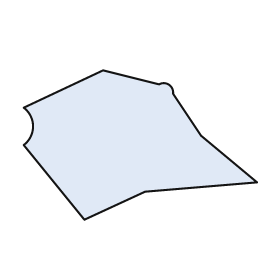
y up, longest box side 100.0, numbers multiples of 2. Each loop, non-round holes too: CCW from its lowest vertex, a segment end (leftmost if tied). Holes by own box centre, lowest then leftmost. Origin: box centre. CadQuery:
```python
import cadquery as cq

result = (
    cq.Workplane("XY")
    .moveTo(-24.0, -32.0)
    .lineTo(2.0, -20.0)
    .lineTo(50.0, -16.0)
    .lineTo(26.0, 4.0)
    .lineTo(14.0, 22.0)
    .threePointArc((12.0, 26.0), (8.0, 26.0))
    .lineTo(-16.0, 32.0)
    .lineTo(-50.0, 16.0)
    .threePointArc((-46.0, 8.0), (-50.0, 0.0))
    .close()
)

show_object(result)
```